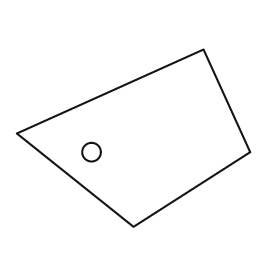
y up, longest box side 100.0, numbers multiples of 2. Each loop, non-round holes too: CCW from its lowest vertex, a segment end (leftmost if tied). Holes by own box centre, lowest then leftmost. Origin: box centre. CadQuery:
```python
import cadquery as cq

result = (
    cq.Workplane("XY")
    .moveTo(0.0, -38.0)
    .lineTo(50.0, -6.0)
    .lineTo(30.0, 38.0)
    .lineTo(-50.0, 2.0)
    .close()
    .moveTo(-18.0, -6.0)
    .circle(4.0)
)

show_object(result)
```